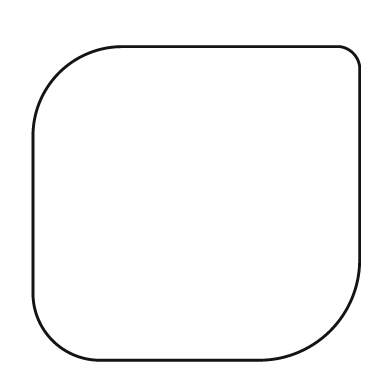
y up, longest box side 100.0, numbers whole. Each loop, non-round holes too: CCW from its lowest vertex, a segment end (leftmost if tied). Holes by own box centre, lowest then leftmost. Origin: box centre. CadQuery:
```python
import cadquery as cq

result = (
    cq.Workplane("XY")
    .moveTo(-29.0, -48.0)
    .lineTo(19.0, -48.0)
    .threePointArc((41.0, -39.0), (50.0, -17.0))
    .lineTo(50.0, 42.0)
    .threePointArc((48.0, 46.0), (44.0, 48.0))
    .lineTo(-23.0, 48.0)
    .threePointArc((-42.0, 40.0), (-50.0, 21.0))
    .lineTo(-50.0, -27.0)
    .threePointArc((-44.0, -42.0), (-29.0, -48.0))
    .close()
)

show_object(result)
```